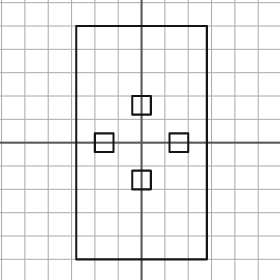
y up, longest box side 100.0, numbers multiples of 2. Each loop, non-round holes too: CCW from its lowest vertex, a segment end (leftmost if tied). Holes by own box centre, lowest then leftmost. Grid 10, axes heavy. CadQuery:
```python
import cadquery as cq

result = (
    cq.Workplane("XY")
    .moveTo(-28.0, -50.0)
    .lineTo(28.0, -50.0)
    .lineTo(28.0, 50.0)
    .lineTo(-28.0, 50.0)
    .close()
    .moveTo(-4.0, -20.0)
    .lineTo(4.0, -20.0)
    .lineTo(4.0, -12.0)
    .lineTo(-4.0, -12.0)
    .close()
    .moveTo(-20.0, -4.0)
    .lineTo(-12.0, -4.0)
    .lineTo(-12.0, 4.0)
    .lineTo(-20.0, 4.0)
    .close()
    .moveTo(12.0, -4.0)
    .lineTo(20.0, -4.0)
    .lineTo(20.0, 4.0)
    .lineTo(12.0, 4.0)
    .close()
    .moveTo(-4.0, 12.0)
    .lineTo(4.0, 12.0)
    .lineTo(4.0, 20.0)
    .lineTo(-4.0, 20.0)
    .close()
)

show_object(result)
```